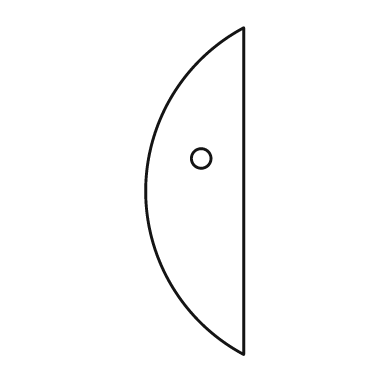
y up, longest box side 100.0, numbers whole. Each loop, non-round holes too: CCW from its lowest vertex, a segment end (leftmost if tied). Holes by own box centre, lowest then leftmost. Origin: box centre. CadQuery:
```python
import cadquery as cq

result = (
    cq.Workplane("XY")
    .moveTo(15.0, -50.0)
    .lineTo(15.0, 50.0)
    .threePointArc((-15.0, 0.0), (15.0, -50.0))
    .close()
    .moveTo(2.0, 10.0)
    .circle(3.0)
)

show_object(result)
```